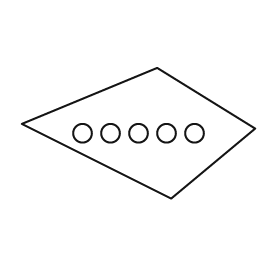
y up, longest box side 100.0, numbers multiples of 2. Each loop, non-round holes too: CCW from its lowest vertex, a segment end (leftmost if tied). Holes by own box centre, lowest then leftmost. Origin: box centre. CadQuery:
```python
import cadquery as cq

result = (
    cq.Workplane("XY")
    .moveTo(14.0, -28.0)
    .lineTo(50.0, 2.0)
    .lineTo(8.0, 28.0)
    .lineTo(-50.0, 4.0)
    .close()
    .moveTo(-24.0, 0.0)
    .circle(4.0)
    .moveTo(-12.0, 0.0)
    .circle(4.0)
    .moveTo(0.0, 0.0)
    .circle(4.0)
    .moveTo(12.0, 0.0)
    .circle(4.0)
    .moveTo(24.0, 0.0)
    .circle(4.0)
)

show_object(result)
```